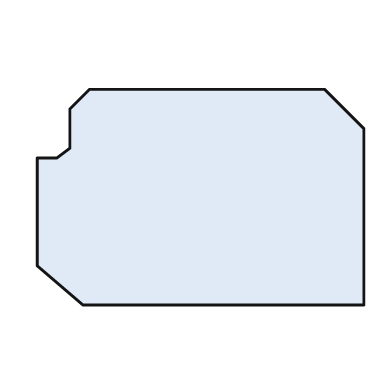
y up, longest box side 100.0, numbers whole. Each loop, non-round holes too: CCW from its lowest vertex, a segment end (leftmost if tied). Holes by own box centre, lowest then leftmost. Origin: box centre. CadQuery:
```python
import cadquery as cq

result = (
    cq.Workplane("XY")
    .moveTo(-36.0, -33.0)
    .lineTo(50.0, -33.0)
    .lineTo(50.0, 21.0)
    .lineTo(38.0, 33.0)
    .lineTo(-34.0, 33.0)
    .lineTo(-40.0, 27.0)
    .lineTo(-40.0, 15.0)
    .lineTo(-44.0, 12.0)
    .lineTo(-50.0, 12.0)
    .lineTo(-50.0, -21.0)
    .close()
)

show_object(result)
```